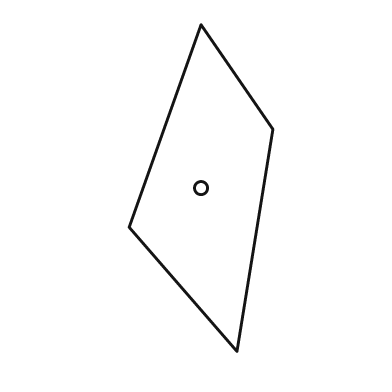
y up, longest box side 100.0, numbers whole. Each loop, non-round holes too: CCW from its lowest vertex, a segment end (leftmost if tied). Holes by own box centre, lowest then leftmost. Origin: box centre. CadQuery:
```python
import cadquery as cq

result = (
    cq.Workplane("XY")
    .moveTo(11.0, -50.0)
    .lineTo(22.0, 18.0)
    .lineTo(0.0, 50.0)
    .lineTo(-22.0, -12.0)
    .close()
    .moveTo(0.0, 0.0)
    .circle(2.0)
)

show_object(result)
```